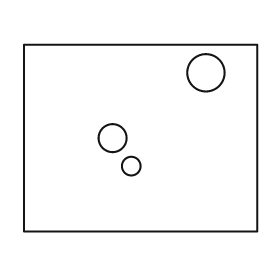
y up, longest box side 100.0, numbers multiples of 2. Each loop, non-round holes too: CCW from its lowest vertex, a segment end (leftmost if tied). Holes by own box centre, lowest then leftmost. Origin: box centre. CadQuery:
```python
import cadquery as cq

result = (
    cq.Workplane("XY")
    .moveTo(-50.0, -40.0)
    .lineTo(50.0, -40.0)
    .lineTo(50.0, 40.0)
    .lineTo(-50.0, 40.0)
    .close()
    .moveTo(-4.0, -12.0)
    .circle(4.0)
    .moveTo(-12.0, 0.0)
    .circle(6.0)
    .moveTo(28.0, 28.0)
    .circle(8.0)
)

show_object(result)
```